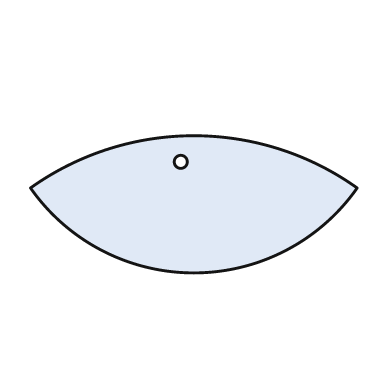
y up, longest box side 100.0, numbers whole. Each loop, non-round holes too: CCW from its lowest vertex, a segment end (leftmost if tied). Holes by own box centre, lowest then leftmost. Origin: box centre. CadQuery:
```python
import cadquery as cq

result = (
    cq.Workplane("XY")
    .moveTo(-50.0, 5.0)
    .threePointArc((0.0, -21.0), (50.0, 5.0))
    .threePointArc((0.0, 21.0), (-50.0, 5.0))
    .close()
    .moveTo(-4.0, 13.0)
    .circle(2.0)
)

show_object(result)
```